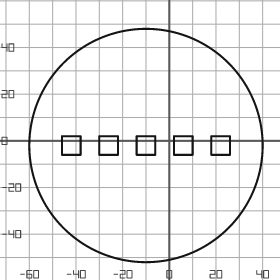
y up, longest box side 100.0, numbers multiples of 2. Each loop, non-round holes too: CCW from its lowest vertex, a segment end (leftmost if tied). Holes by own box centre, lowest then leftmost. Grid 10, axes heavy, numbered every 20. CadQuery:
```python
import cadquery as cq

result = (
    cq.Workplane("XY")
    .moveTo(-10.0, -2.0)
    .circle(50.0)
    .moveTo(-46.0, -6.0)
    .lineTo(-38.0, -6.0)
    .lineTo(-38.0, 2.0)
    .lineTo(-46.0, 2.0)
    .close()
    .moveTo(-30.0, -6.0)
    .lineTo(-22.0, -6.0)
    .lineTo(-22.0, 2.0)
    .lineTo(-30.0, 2.0)
    .close()
    .moveTo(-14.0, -6.0)
    .lineTo(-6.0, -6.0)
    .lineTo(-6.0, 2.0)
    .lineTo(-14.0, 2.0)
    .close()
    .moveTo(2.0, -6.0)
    .lineTo(10.0, -6.0)
    .lineTo(10.0, 2.0)
    .lineTo(2.0, 2.0)
    .close()
    .moveTo(18.0, -6.0)
    .lineTo(26.0, -6.0)
    .lineTo(26.0, 2.0)
    .lineTo(18.0, 2.0)
    .close()
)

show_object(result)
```